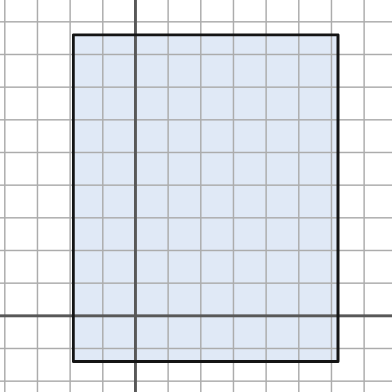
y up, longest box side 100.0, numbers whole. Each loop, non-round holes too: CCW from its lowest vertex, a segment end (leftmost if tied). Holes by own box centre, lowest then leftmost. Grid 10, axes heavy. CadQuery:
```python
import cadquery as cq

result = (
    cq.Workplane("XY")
    .moveTo(-19.0, -14.0)
    .lineTo(62.0, -14.0)
    .lineTo(62.0, 86.0)
    .lineTo(-19.0, 86.0)
    .close()
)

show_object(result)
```